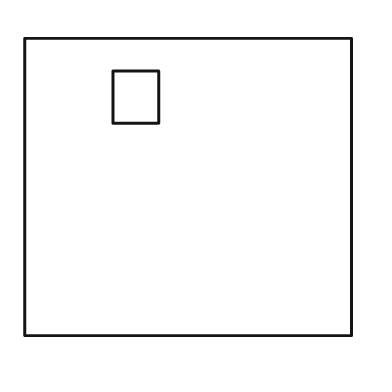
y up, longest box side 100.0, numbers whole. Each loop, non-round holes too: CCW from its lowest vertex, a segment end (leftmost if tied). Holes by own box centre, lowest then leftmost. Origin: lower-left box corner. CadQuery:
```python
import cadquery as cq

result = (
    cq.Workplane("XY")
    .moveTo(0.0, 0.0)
    .lineTo(100.0, 0.0)
    .lineTo(100.0, 91.0)
    .lineTo(0.0, 91.0)
    .close()
    .moveTo(27.0, 65.0)
    .lineTo(41.0, 65.0)
    .lineTo(41.0, 81.0)
    .lineTo(27.0, 81.0)
    .close()
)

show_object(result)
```